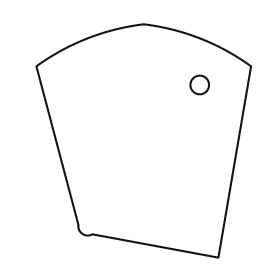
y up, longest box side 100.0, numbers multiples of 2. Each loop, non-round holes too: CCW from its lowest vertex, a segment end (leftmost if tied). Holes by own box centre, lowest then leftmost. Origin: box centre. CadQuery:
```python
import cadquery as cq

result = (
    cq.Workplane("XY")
    .moveTo(32.0, -50.0)
    .lineTo(46.0, 32.0)
    .threePointArc((24.0, 44.0), (0.0, 50.0))
    .threePointArc((-24.0, 44.0), (-46.0, 32.0))
    .lineTo(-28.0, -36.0)
    .threePointArc((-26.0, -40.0), (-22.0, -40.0))
    .close()
    .moveTo(24.0, 24.0)
    .circle(4.0)
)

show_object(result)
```